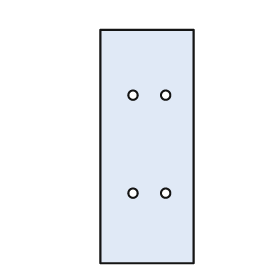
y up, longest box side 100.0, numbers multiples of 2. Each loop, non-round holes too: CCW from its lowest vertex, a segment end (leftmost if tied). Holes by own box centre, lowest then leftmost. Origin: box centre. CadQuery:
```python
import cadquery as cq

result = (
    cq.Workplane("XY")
    .moveTo(-20.0, -50.0)
    .lineTo(20.0, -50.0)
    .lineTo(20.0, 50.0)
    .lineTo(-20.0, 50.0)
    .close()
    .moveTo(-6.0, -20.0)
    .circle(2.0)
    .moveTo(8.0, -20.0)
    .circle(2.0)
    .moveTo(-6.0, 22.0)
    .circle(2.0)
    .moveTo(8.0, 22.0)
    .circle(2.0)
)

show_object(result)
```